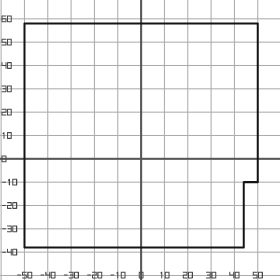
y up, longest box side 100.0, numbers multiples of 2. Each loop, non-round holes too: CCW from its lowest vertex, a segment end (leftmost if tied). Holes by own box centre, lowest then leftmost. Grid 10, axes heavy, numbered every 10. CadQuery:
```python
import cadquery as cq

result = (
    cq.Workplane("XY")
    .moveTo(-50.0, -38.0)
    .lineTo(44.0, -38.0)
    .lineTo(44.0, -10.0)
    .lineTo(50.0, -10.0)
    .lineTo(50.0, 58.0)
    .lineTo(-50.0, 58.0)
    .close()
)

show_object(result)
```